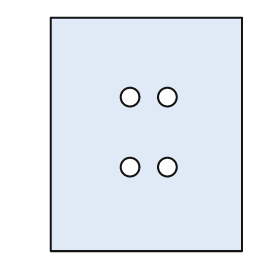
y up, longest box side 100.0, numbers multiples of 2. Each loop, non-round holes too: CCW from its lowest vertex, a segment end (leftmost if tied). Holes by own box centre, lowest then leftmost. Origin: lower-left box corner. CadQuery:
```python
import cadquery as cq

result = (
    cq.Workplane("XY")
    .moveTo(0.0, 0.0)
    .lineTo(82.0, 0.0)
    .lineTo(82.0, 100.0)
    .lineTo(0.0, 100.0)
    .close()
    .moveTo(34.0, 36.0)
    .circle(4.0)
    .moveTo(50.0, 36.0)
    .circle(4.0)
    .moveTo(34.0, 66.0)
    .circle(4.0)
    .moveTo(50.0, 66.0)
    .circle(4.0)
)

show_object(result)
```